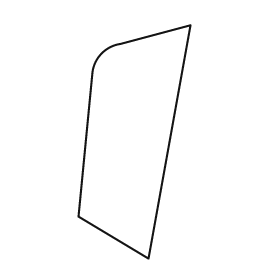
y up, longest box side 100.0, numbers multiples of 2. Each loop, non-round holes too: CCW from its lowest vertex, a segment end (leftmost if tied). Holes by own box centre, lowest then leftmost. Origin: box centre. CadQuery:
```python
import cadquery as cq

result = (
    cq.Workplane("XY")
    .moveTo(6.0, -50.0)
    .lineTo(24.0, 50.0)
    .lineTo(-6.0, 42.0)
    .threePointArc((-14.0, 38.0), (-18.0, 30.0))
    .lineTo(-24.0, -32.0)
    .close()
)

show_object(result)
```